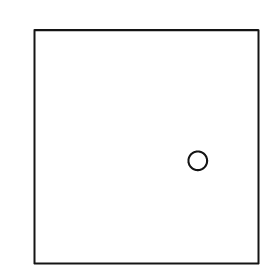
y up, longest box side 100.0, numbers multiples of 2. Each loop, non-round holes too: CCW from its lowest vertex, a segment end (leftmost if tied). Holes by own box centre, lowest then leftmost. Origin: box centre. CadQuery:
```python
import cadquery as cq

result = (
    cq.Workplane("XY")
    .moveTo(-48.0, -50.0)
    .lineTo(48.0, -50.0)
    .lineTo(48.0, 50.0)
    .lineTo(-48.0, 50.0)
    .close()
    .moveTo(22.0, -6.0)
    .circle(4.0)
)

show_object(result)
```